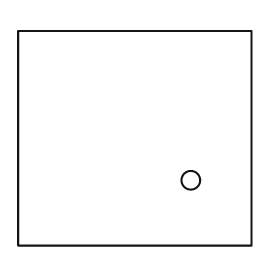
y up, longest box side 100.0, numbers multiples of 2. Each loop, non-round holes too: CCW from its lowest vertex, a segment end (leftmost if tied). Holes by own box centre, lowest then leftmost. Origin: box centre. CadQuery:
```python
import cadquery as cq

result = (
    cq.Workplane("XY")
    .moveTo(-50.0, -46.0)
    .lineTo(50.0, -46.0)
    .lineTo(50.0, 46.0)
    .lineTo(-50.0, 46.0)
    .close()
    .moveTo(24.0, -18.0)
    .circle(4.0)
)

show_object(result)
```